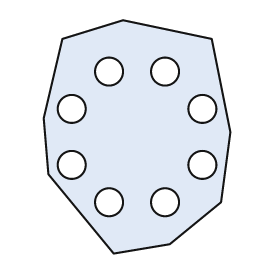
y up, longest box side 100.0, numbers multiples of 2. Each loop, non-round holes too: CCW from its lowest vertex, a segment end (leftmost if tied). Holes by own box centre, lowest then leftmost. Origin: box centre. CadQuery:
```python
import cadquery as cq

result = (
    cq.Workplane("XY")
    .moveTo(-10.0, -50.0)
    .lineTo(14.0, -46.0)
    .lineTo(36.0, -28.0)
    .lineTo(40.0, 2.0)
    .lineTo(32.0, 42.0)
    .lineTo(-6.0, 50.0)
    .lineTo(-32.0, 42.0)
    .lineTo(-40.0, 8.0)
    .lineTo(-38.0, -16.0)
    .close()
    .moveTo(-12.0, -28.0)
    .circle(6.0)
    .moveTo(12.0, -28.0)
    .circle(6.0)
    .moveTo(-28.0, -12.0)
    .circle(6.0)
    .moveTo(28.0, -12.0)
    .circle(6.0)
    .moveTo(-28.0, 12.0)
    .circle(6.0)
    .moveTo(28.0, 12.0)
    .circle(6.0)
    .moveTo(-12.0, 28.0)
    .circle(6.0)
    .moveTo(12.0, 28.0)
    .circle(6.0)
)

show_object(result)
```